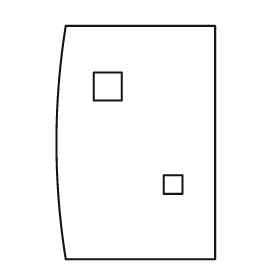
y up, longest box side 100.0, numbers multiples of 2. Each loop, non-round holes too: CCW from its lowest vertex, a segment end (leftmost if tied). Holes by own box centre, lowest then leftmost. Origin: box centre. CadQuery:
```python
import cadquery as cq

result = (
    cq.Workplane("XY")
    .moveTo(-30.0, -50.0)
    .lineTo(34.0, -50.0)
    .lineTo(34.0, 50.0)
    .lineTo(-30.0, 50.0)
    .threePointArc((-34.0, 0.0), (-30.0, -50.0))
    .close()
    .moveTo(12.0, -22.0)
    .lineTo(20.0, -22.0)
    .lineTo(20.0, -14.0)
    .lineTo(12.0, -14.0)
    .close()
    .moveTo(-18.0, 18.0)
    .lineTo(-6.0, 18.0)
    .lineTo(-6.0, 30.0)
    .lineTo(-18.0, 30.0)
    .close()
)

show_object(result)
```